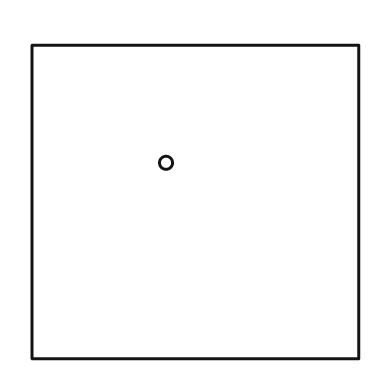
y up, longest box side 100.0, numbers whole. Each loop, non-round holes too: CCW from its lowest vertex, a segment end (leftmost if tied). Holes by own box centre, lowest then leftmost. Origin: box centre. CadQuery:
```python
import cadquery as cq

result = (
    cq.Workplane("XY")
    .moveTo(-50.0, -48.0)
    .lineTo(50.0, -48.0)
    .lineTo(50.0, 48.0)
    .lineTo(-50.0, 48.0)
    .close()
    .moveTo(-9.0, 12.0)
    .circle(2.0)
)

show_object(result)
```